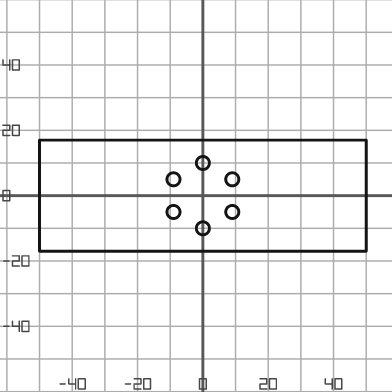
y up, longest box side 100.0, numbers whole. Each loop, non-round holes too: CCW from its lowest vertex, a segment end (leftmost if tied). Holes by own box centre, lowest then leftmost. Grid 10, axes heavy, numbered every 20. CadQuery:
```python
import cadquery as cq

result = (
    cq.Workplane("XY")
    .moveTo(-50.0, -17.0)
    .lineTo(50.0, -17.0)
    .lineTo(50.0, 17.0)
    .lineTo(-50.0, 17.0)
    .close()
    .moveTo(0.0, -10.0)
    .circle(2.0)
    .moveTo(-9.0, -5.0)
    .circle(2.0)
    .moveTo(9.0, -5.0)
    .circle(2.0)
    .moveTo(-9.0, 5.0)
    .circle(2.0)
    .moveTo(9.0, 5.0)
    .circle(2.0)
    .moveTo(0.0, 10.0)
    .circle(2.0)
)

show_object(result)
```